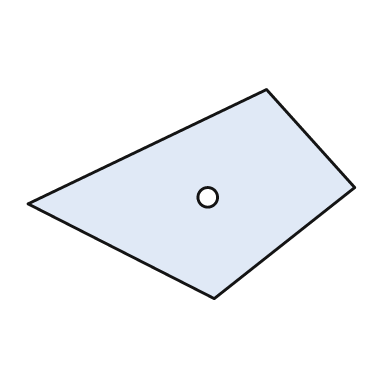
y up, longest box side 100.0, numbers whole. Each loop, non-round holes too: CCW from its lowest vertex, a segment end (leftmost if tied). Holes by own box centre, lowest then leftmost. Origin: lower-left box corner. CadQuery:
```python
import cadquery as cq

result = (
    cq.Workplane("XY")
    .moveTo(57.0, 0.0)
    .lineTo(100.0, 34.0)
    .lineTo(73.0, 64.0)
    .lineTo(0.0, 29.0)
    .close()
    .moveTo(55.0, 31.0)
    .circle(3.0)
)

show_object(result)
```